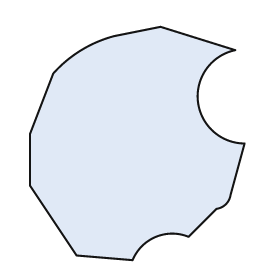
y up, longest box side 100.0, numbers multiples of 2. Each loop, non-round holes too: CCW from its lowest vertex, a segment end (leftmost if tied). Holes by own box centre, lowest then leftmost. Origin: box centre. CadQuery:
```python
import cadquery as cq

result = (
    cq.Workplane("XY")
    .moveTo(-2.0, -50.0)
    .threePointArc((8.0, -40.0), (22.0, -40.0))
    .lineTo(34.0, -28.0)
    .threePointArc((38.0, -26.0), (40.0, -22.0))
    .lineTo(46.0, 0.0)
    .threePointArc((26.0, 18.0), (42.0, 40.0))
    .lineTo(10.0, 50.0)
    .lineTo(-10.0, 46.0)
    .threePointArc((-24.0, 40.0), (-36.0, 30.0))
    .lineTo(-46.0, 4.0)
    .lineTo(-46.0, -18.0)
    .lineTo(-26.0, -48.0)
    .close()
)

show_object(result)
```